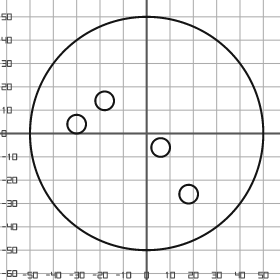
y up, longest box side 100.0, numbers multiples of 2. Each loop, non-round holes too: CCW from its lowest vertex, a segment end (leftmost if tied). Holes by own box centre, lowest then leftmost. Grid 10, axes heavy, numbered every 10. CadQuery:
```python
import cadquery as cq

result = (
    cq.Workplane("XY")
    .moveTo(0.0, 0.0)
    .circle(50.0)
    .moveTo(18.0, -26.0)
    .circle(4.0)
    .moveTo(6.0, -6.0)
    .circle(4.0)
    .moveTo(-30.0, 4.0)
    .circle(4.0)
    .moveTo(-18.0, 14.0)
    .circle(4.0)
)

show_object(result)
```